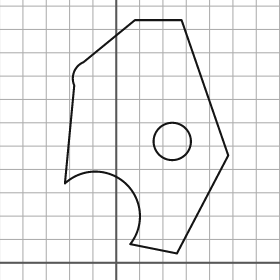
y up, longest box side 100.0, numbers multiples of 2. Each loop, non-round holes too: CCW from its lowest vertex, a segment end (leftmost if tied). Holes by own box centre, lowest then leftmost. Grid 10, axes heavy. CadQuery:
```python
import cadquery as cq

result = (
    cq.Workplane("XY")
    .moveTo(26.0, 4.0)
    .lineTo(48.0, 46.0)
    .lineTo(28.0, 104.0)
    .lineTo(8.0, 104.0)
    .lineTo(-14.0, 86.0)
    .threePointArc((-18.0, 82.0), (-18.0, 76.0))
    .lineTo(-22.0, 34.0)
    .threePointArc((4.0, 34.0), (6.0, 8.0))
    .close()
    .moveTo(24.0, 52.0)
    .circle(8.0)
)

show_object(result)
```